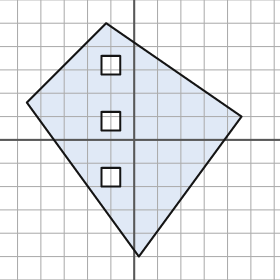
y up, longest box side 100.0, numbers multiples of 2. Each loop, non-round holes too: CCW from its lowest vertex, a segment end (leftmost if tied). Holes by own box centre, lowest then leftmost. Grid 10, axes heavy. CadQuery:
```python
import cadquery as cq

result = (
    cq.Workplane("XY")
    .moveTo(2.0, -50.0)
    .lineTo(46.0, 10.0)
    .lineTo(-12.0, 50.0)
    .lineTo(-46.0, 16.0)
    .close()
    .moveTo(-14.0, -20.0)
    .lineTo(-6.0, -20.0)
    .lineTo(-6.0, -12.0)
    .lineTo(-14.0, -12.0)
    .close()
    .moveTo(-14.0, 4.0)
    .lineTo(-6.0, 4.0)
    .lineTo(-6.0, 12.0)
    .lineTo(-14.0, 12.0)
    .close()
    .moveTo(-14.0, 28.0)
    .lineTo(-6.0, 28.0)
    .lineTo(-6.0, 36.0)
    .lineTo(-14.0, 36.0)
    .close()
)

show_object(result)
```